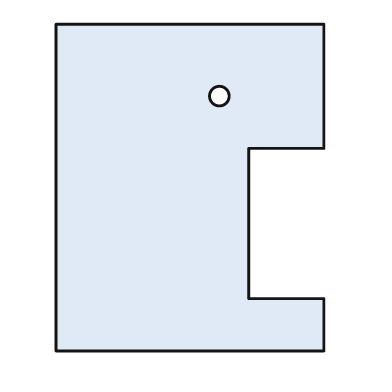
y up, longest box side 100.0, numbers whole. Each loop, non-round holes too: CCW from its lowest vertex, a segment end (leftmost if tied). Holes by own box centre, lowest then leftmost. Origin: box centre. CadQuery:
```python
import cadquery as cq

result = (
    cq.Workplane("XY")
    .moveTo(-41.0, -50.0)
    .lineTo(41.0, -50.0)
    .lineTo(41.0, -34.0)
    .lineTo(18.0, -34.0)
    .lineTo(18.0, 12.0)
    .lineTo(41.0, 12.0)
    .lineTo(41.0, 50.0)
    .lineTo(-41.0, 50.0)
    .close()
    .moveTo(9.0, 28.0)
    .circle(3.0)
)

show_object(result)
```